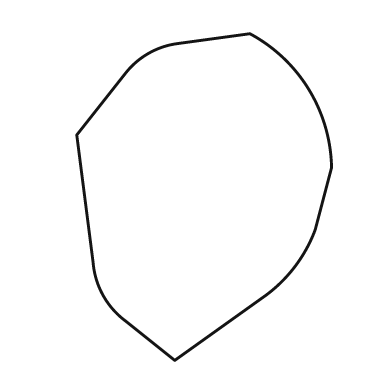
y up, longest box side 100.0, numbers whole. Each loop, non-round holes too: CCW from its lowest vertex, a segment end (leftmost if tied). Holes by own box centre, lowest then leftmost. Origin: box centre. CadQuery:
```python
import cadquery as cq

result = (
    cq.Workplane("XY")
    .moveTo(-9.0, -50.0)
    .lineTo(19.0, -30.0)
    .threePointArc((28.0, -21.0), (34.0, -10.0))
    .lineTo(39.0, 9.0)
    .threePointArc((32.0, 33.0), (14.0, 50.0))
    .lineTo(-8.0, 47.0)
    .threePointArc((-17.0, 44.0), (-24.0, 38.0))
    .lineTo(-39.0, 19.0)
    .lineTo(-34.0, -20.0)
    .threePointArc((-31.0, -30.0), (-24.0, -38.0))
    .close()
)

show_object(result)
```